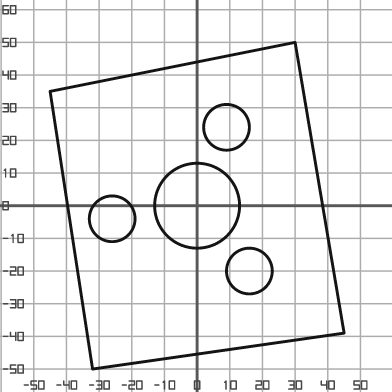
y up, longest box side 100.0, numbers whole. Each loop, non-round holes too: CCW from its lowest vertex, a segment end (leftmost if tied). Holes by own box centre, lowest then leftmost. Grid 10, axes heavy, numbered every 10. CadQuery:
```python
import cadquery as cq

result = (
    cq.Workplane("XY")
    .moveTo(-32.0, -50.0)
    .lineTo(45.0, -39.0)
    .lineTo(30.0, 50.0)
    .lineTo(-45.0, 35.0)
    .close()
    .moveTo(16.0, -20.0)
    .circle(7.0)
    .moveTo(-26.0, -4.0)
    .circle(7.0)
    .moveTo(0.0, 0.0)
    .circle(13.0)
    .moveTo(9.0, 24.0)
    .circle(7.0)
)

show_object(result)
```